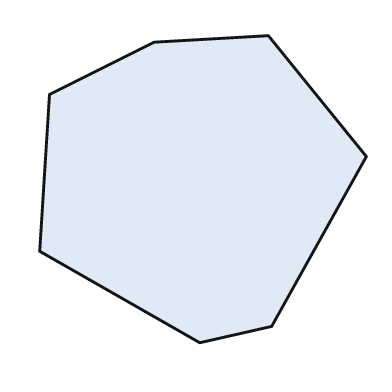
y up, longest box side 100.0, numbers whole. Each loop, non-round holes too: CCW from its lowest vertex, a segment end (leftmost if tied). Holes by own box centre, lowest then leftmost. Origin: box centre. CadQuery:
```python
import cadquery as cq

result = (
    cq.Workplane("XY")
    .moveTo(-1.0, -47.0)
    .lineTo(21.0, -42.0)
    .lineTo(50.0, 10.0)
    .lineTo(20.0, 47.0)
    .lineTo(-15.0, 45.0)
    .lineTo(-47.0, 29.0)
    .lineTo(-50.0, -19.0)
    .close()
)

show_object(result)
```